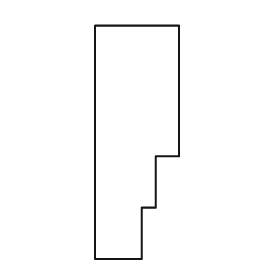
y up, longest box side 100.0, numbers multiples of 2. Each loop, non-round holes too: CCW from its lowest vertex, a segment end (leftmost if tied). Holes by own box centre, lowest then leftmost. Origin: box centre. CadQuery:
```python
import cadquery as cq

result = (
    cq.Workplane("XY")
    .moveTo(-18.0, -50.0)
    .lineTo(2.0, -50.0)
    .lineTo(2.0, -28.0)
    .lineTo(8.0, -28.0)
    .lineTo(8.0, -6.0)
    .lineTo(18.0, -6.0)
    .lineTo(18.0, 50.0)
    .lineTo(-18.0, 50.0)
    .close()
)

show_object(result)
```